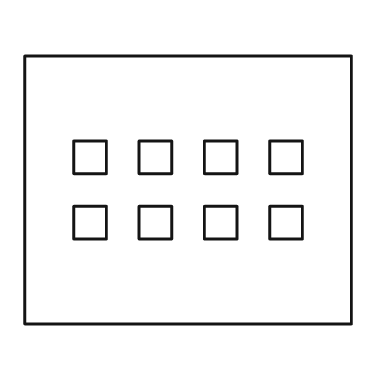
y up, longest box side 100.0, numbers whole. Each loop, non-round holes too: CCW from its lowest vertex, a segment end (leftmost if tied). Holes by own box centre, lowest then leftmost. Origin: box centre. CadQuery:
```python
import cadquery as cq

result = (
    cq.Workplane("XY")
    .moveTo(-50.0, -41.0)
    .lineTo(50.0, -41.0)
    .lineTo(50.0, 41.0)
    .lineTo(-50.0, 41.0)
    .close()
    .moveTo(-35.0, -15.0)
    .lineTo(-25.0, -15.0)
    .lineTo(-25.0, -5.0)
    .lineTo(-35.0, -5.0)
    .close()
    .moveTo(-15.0, -15.0)
    .lineTo(-5.0, -15.0)
    .lineTo(-5.0, -5.0)
    .lineTo(-15.0, -5.0)
    .close()
    .moveTo(5.0, -15.0)
    .lineTo(15.0, -15.0)
    .lineTo(15.0, -5.0)
    .lineTo(5.0, -5.0)
    .close()
    .moveTo(25.0, -15.0)
    .lineTo(35.0, -15.0)
    .lineTo(35.0, -5.0)
    .lineTo(25.0, -5.0)
    .close()
    .moveTo(-35.0, 5.0)
    .lineTo(-25.0, 5.0)
    .lineTo(-25.0, 15.0)
    .lineTo(-35.0, 15.0)
    .close()
    .moveTo(-15.0, 5.0)
    .lineTo(-5.0, 5.0)
    .lineTo(-5.0, 15.0)
    .lineTo(-15.0, 15.0)
    .close()
    .moveTo(5.0, 5.0)
    .lineTo(15.0, 5.0)
    .lineTo(15.0, 15.0)
    .lineTo(5.0, 15.0)
    .close()
    .moveTo(25.0, 5.0)
    .lineTo(35.0, 5.0)
    .lineTo(35.0, 15.0)
    .lineTo(25.0, 15.0)
    .close()
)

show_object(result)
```